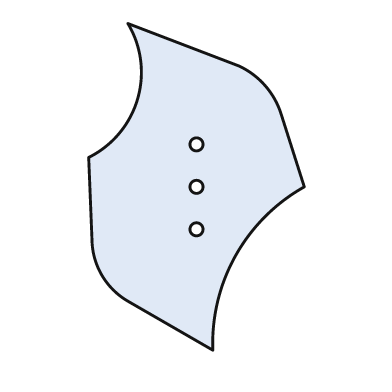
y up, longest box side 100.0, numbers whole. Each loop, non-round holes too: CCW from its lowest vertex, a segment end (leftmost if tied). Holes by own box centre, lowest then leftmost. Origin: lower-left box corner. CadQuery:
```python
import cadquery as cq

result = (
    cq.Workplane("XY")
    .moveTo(38.0, 0.0)
    .threePointArc((45.0, 29.0), (66.0, 50.0))
    .lineTo(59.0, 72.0)
    .threePointArc((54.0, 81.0), (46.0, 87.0))
    .lineTo(12.0, 100.0)
    .threePointArc((15.0, 77.0), (0.0, 59.0))
    .lineTo(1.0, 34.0)
    .threePointArc((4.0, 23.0), (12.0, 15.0))
    .close()
    .moveTo(33.0, 37.0)
    .circle(2.0)
    .moveTo(33.0, 50.0)
    .circle(2.0)
    .moveTo(33.0, 63.0)
    .circle(2.0)
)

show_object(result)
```